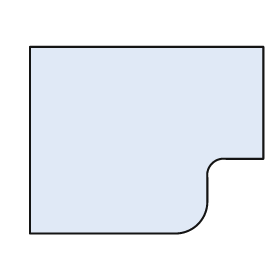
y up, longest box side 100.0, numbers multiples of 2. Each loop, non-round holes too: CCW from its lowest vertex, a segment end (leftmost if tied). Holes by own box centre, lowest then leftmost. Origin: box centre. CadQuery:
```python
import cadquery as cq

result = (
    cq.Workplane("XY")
    .moveTo(-50.0, -40.0)
    .lineTo(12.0, -40.0)
    .threePointArc((22.0, -36.0), (26.0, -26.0))
    .lineTo(26.0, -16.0)
    .threePointArc((28.0, -10.0), (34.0, -8.0))
    .lineTo(50.0, -8.0)
    .lineTo(50.0, 40.0)
    .lineTo(-50.0, 40.0)
    .close()
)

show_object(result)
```